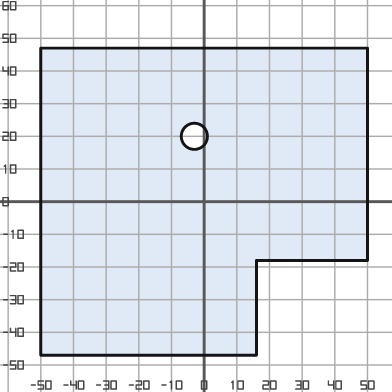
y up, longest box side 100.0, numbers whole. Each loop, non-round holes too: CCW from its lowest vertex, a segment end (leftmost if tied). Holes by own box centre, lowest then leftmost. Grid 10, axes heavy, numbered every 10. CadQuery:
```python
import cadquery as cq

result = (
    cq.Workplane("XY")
    .moveTo(-50.0, -47.0)
    .lineTo(16.0, -47.0)
    .lineTo(16.0, -18.0)
    .lineTo(50.0, -18.0)
    .lineTo(50.0, 47.0)
    .lineTo(-50.0, 47.0)
    .close()
    .moveTo(-3.0, 20.0)
    .circle(4.0)
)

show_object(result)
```